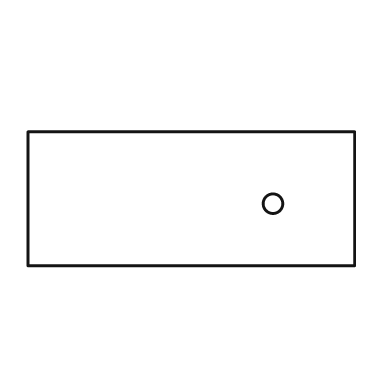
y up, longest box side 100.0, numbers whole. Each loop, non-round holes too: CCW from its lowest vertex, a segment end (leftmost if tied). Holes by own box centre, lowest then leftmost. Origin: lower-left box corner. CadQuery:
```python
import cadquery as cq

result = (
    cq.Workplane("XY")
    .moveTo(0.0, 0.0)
    .lineTo(100.0, 0.0)
    .lineTo(100.0, 41.0)
    .lineTo(0.0, 41.0)
    .close()
    .moveTo(75.0, 19.0)
    .circle(3.0)
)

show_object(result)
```